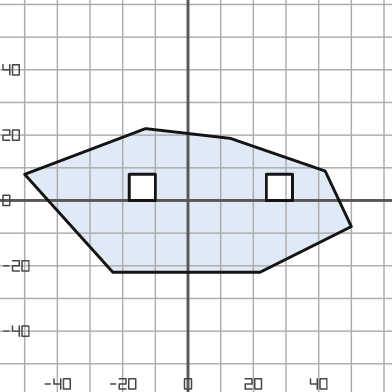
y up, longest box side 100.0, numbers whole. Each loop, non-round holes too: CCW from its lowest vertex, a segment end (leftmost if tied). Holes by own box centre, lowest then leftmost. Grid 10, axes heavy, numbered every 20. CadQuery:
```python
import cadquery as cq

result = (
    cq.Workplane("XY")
    .moveTo(-23.0, -22.0)
    .lineTo(22.0, -22.0)
    .lineTo(50.0, -8.0)
    .lineTo(42.0, 9.0)
    .lineTo(13.0, 19.0)
    .lineTo(-13.0, 22.0)
    .lineTo(-50.0, 8.0)
    .close()
    .moveTo(-18.0, 0.0)
    .lineTo(-10.0, 0.0)
    .lineTo(-10.0, 8.0)
    .lineTo(-18.0, 8.0)
    .close()
    .moveTo(24.0, 0.0)
    .lineTo(32.0, 0.0)
    .lineTo(32.0, 8.0)
    .lineTo(24.0, 8.0)
    .close()
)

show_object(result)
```